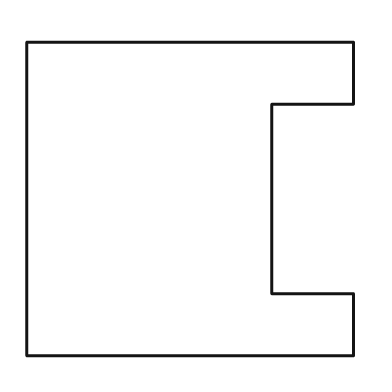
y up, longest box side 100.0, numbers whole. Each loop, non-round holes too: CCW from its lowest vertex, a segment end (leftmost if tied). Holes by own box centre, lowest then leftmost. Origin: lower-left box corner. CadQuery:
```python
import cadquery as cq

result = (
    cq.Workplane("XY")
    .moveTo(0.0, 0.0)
    .lineTo(100.0, 0.0)
    .lineTo(100.0, 19.0)
    .lineTo(75.0, 19.0)
    .lineTo(75.0, 77.0)
    .lineTo(100.0, 77.0)
    .lineTo(100.0, 96.0)
    .lineTo(0.0, 96.0)
    .close()
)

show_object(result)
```